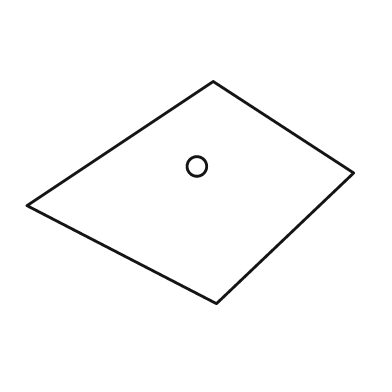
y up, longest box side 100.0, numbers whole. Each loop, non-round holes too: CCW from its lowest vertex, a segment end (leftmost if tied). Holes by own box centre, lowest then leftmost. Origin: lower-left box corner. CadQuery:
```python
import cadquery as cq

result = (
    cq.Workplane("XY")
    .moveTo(58.0, 0.0)
    .lineTo(100.0, 40.0)
    .lineTo(57.0, 68.0)
    .lineTo(0.0, 30.0)
    .close()
    .moveTo(52.0, 42.0)
    .circle(3.0)
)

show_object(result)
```